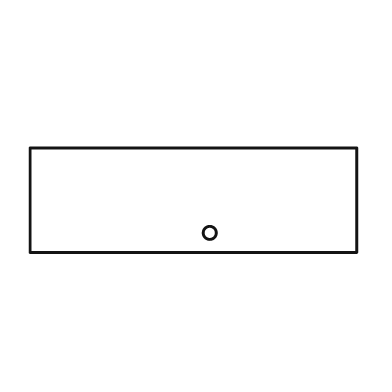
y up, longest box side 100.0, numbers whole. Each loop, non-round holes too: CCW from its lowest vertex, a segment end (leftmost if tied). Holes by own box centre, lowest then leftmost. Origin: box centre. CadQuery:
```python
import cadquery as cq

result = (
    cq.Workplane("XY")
    .moveTo(-50.0, -16.0)
    .lineTo(50.0, -16.0)
    .lineTo(50.0, 16.0)
    .lineTo(-50.0, 16.0)
    .close()
    .moveTo(5.0, -10.0)
    .circle(2.0)
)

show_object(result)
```